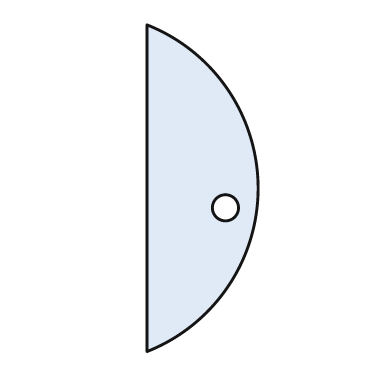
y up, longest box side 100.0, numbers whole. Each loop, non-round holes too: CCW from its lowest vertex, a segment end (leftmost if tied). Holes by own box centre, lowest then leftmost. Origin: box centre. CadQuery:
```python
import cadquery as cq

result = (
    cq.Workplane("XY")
    .moveTo(-17.0, -50.0)
    .threePointArc((17.0, 0.0), (-17.0, 50.0))
    .close()
    .moveTo(7.0, -6.0)
    .circle(4.0)
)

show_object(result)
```